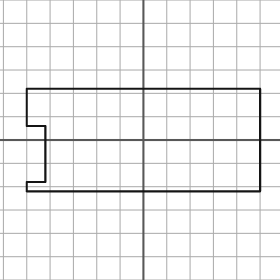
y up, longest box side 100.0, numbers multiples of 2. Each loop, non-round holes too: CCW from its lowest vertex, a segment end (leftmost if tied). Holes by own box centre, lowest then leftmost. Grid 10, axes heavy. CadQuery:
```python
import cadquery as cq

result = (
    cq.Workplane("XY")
    .moveTo(-50.0, -22.0)
    .lineTo(50.0, -22.0)
    .lineTo(50.0, 22.0)
    .lineTo(-50.0, 22.0)
    .lineTo(-50.0, 6.0)
    .lineTo(-42.0, 6.0)
    .lineTo(-42.0, -18.0)
    .lineTo(-50.0, -18.0)
    .close()
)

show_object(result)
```